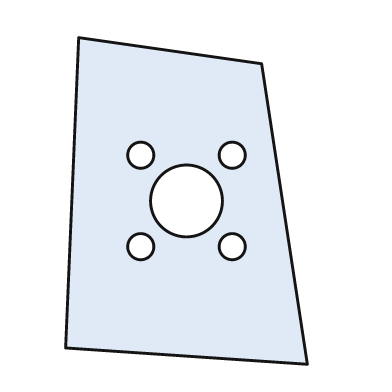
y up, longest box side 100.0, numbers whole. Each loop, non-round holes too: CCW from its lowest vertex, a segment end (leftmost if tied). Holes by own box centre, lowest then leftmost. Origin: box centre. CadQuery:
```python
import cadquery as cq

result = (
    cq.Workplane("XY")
    .moveTo(37.0, -50.0)
    .lineTo(23.0, 42.0)
    .lineTo(-33.0, 50.0)
    .lineTo(-37.0, -45.0)
    .close()
    .moveTo(-14.0, -14.0)
    .circle(4.0)
    .moveTo(14.0, -14.0)
    .circle(4.0)
    .moveTo(0.0, 0.0)
    .circle(11.0)
    .moveTo(-14.0, 14.0)
    .circle(4.0)
    .moveTo(14.0, 14.0)
    .circle(4.0)
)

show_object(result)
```